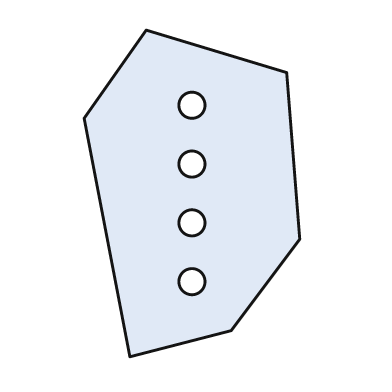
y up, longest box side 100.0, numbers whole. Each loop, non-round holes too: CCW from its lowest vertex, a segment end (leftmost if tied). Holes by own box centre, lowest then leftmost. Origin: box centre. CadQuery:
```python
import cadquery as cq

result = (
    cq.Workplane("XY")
    .moveTo(-19.0, -50.0)
    .lineTo(12.0, -42.0)
    .lineTo(33.0, -14.0)
    .lineTo(29.0, 37.0)
    .lineTo(-14.0, 50.0)
    .lineTo(-33.0, 23.0)
    .close()
    .moveTo(0.0, -27.0)
    .circle(4.0)
    .moveTo(0.0, -9.0)
    .circle(4.0)
    .moveTo(0.0, 9.0)
    .circle(4.0)
    .moveTo(0.0, 27.0)
    .circle(4.0)
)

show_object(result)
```